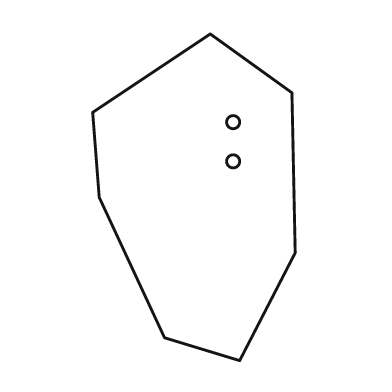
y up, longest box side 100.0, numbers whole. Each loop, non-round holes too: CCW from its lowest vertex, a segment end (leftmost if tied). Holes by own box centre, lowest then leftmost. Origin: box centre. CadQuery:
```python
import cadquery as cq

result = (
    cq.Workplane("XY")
    .moveTo(14.0, -50.0)
    .lineTo(31.0, -17.0)
    .lineTo(30.0, 32.0)
    .lineTo(5.0, 50.0)
    .lineTo(-31.0, 26.0)
    .lineTo(-29.0, 0.0)
    .lineTo(-9.0, -43.0)
    .close()
    .moveTo(12.0, 11.0)
    .circle(2.0)
    .moveTo(12.0, 23.0)
    .circle(2.0)
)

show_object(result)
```